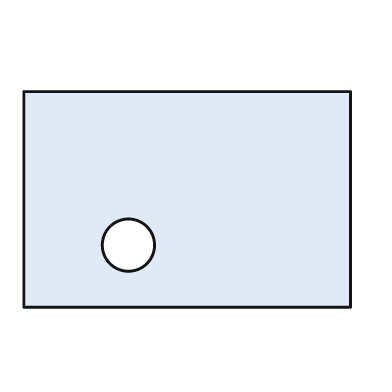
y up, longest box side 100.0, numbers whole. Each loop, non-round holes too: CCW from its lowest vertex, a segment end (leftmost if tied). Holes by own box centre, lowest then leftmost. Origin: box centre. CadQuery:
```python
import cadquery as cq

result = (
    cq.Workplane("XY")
    .moveTo(-50.0, -33.0)
    .lineTo(50.0, -33.0)
    .lineTo(50.0, 33.0)
    .lineTo(-50.0, 33.0)
    .close()
    .moveTo(-18.0, -14.0)
    .circle(8.0)
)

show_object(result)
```